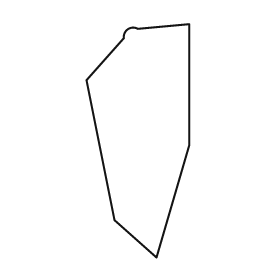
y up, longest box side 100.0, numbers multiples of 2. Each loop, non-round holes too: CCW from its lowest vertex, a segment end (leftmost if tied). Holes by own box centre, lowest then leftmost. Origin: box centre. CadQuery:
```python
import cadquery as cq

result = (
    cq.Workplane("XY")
    .moveTo(8.0, -50.0)
    .lineTo(22.0, -2.0)
    .lineTo(22.0, 50.0)
    .lineTo(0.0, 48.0)
    .threePointArc((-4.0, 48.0), (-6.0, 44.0))
    .lineTo(-22.0, 26.0)
    .lineTo(-10.0, -34.0)
    .close()
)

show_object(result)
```